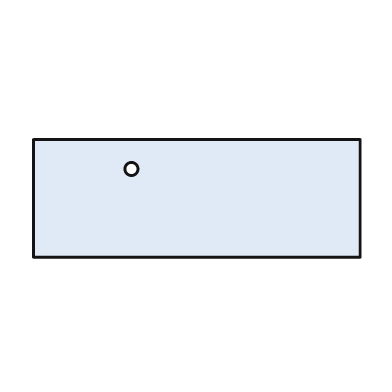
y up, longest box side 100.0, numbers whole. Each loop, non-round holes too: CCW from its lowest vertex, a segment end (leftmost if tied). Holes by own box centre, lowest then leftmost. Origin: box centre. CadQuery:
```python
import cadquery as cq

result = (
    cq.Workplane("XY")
    .moveTo(-50.0, -18.0)
    .lineTo(50.0, -18.0)
    .lineTo(50.0, 18.0)
    .lineTo(-50.0, 18.0)
    .close()
    .moveTo(-20.0, 9.0)
    .circle(2.0)
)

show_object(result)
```